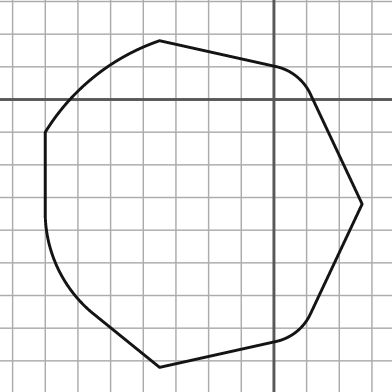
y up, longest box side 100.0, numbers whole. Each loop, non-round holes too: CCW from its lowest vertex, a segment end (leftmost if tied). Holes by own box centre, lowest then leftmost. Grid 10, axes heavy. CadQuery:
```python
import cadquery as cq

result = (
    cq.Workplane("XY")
    .moveTo(-35.0, -82.0)
    .lineTo(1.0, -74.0)
    .threePointArc((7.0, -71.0), (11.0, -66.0))
    .lineTo(27.0, -32.0)
    .lineTo(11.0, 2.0)
    .threePointArc((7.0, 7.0), (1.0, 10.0))
    .lineTo(-35.0, 18.0)
    .threePointArc((-55.0, 7.0), (-70.0, -10.0))
    .lineTo(-70.0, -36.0)
    .threePointArc((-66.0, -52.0), (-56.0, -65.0))
    .close()
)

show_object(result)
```